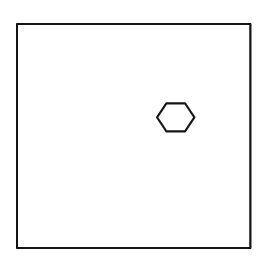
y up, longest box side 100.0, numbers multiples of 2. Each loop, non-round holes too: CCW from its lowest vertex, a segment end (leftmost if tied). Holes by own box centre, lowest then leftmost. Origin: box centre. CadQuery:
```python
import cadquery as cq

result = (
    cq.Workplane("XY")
    .moveTo(-50.0, -48.0)
    .lineTo(50.0, -48.0)
    .lineTo(50.0, 48.0)
    .lineTo(-50.0, 48.0)
    .close()
    .moveTo(14.0, 2.0)
    .lineTo(22.0, 2.0)
    .lineTo(26.0, 8.0)
    .lineTo(22.0, 14.0)
    .lineTo(14.0, 14.0)
    .lineTo(10.0, 8.0)
    .close()
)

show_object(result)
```